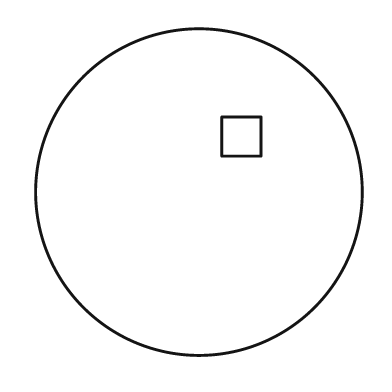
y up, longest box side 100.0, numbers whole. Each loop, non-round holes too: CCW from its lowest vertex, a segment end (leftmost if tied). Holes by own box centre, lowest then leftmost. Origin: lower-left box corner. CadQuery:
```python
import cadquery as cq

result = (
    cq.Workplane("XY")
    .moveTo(50.0, 50.0)
    .circle(50.0)
    .moveTo(57.0, 61.0)
    .lineTo(69.0, 61.0)
    .lineTo(69.0, 73.0)
    .lineTo(57.0, 73.0)
    .close()
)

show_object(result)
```